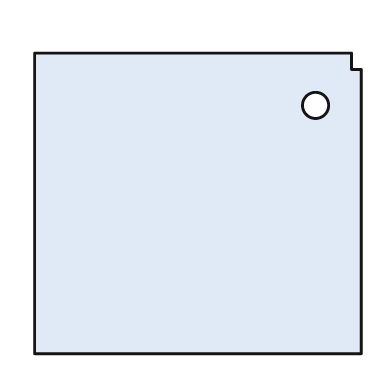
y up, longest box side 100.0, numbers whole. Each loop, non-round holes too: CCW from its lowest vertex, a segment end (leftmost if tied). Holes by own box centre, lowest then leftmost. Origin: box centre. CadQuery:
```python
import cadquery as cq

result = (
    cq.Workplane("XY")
    .moveTo(-50.0, -46.0)
    .lineTo(50.0, -46.0)
    .lineTo(50.0, 41.0)
    .lineTo(47.0, 41.0)
    .lineTo(47.0, 46.0)
    .lineTo(-50.0, 46.0)
    .close()
    .moveTo(36.0, 30.0)
    .circle(4.0)
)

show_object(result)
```